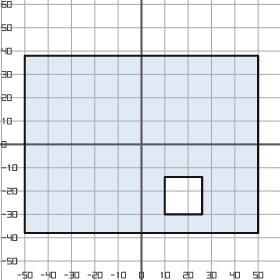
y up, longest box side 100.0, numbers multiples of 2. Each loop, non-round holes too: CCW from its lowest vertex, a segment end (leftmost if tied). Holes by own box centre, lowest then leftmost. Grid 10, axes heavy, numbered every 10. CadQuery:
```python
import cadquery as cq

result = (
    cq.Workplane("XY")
    .moveTo(-50.0, -38.0)
    .lineTo(50.0, -38.0)
    .lineTo(50.0, 38.0)
    .lineTo(-50.0, 38.0)
    .close()
    .moveTo(10.0, -30.0)
    .lineTo(26.0, -30.0)
    .lineTo(26.0, -14.0)
    .lineTo(10.0, -14.0)
    .close()
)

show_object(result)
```